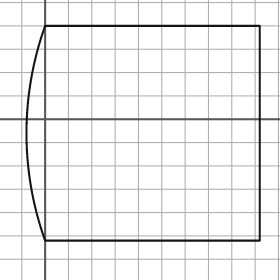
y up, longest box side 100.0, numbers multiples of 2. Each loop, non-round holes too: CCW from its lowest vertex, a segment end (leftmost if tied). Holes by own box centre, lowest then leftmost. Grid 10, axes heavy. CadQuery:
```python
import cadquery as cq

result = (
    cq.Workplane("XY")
    .moveTo(0.0, -52.0)
    .lineTo(92.0, -52.0)
    .lineTo(92.0, 40.0)
    .lineTo(0.0, 40.0)
    .threePointArc((-8.0, -6.0), (0.0, -52.0))
    .close()
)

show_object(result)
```